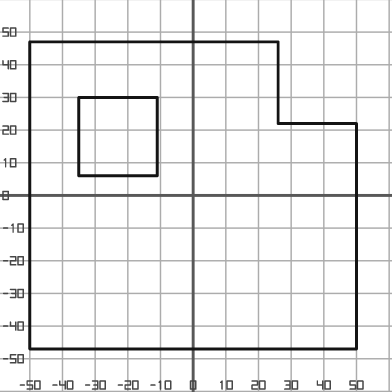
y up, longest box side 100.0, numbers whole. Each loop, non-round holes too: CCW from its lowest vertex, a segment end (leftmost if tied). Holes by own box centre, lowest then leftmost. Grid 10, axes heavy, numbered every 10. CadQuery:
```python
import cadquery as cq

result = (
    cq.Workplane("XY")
    .moveTo(-50.0, -47.0)
    .lineTo(50.0, -47.0)
    .lineTo(50.0, 22.0)
    .lineTo(26.0, 22.0)
    .lineTo(26.0, 47.0)
    .lineTo(-50.0, 47.0)
    .close()
    .moveTo(-35.0, 6.0)
    .lineTo(-11.0, 6.0)
    .lineTo(-11.0, 30.0)
    .lineTo(-35.0, 30.0)
    .close()
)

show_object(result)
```